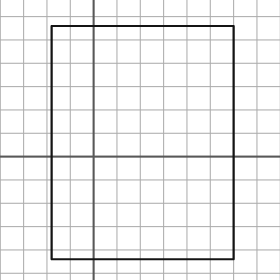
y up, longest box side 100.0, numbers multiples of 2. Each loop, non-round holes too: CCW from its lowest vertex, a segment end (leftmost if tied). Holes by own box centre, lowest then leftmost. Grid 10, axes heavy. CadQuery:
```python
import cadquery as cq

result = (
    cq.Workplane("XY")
    .moveTo(-18.0, -44.0)
    .lineTo(60.0, -44.0)
    .lineTo(60.0, 56.0)
    .lineTo(-18.0, 56.0)
    .close()
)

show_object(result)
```